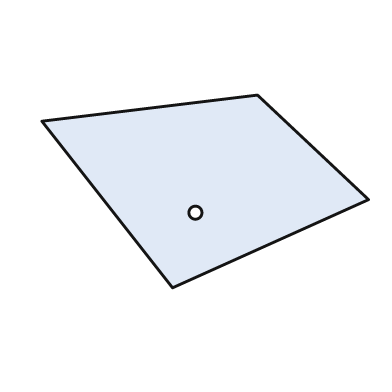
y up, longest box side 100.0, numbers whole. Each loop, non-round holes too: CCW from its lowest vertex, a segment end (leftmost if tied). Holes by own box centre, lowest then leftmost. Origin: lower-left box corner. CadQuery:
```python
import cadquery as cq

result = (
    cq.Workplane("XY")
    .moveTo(40.0, 0.0)
    .lineTo(100.0, 27.0)
    .lineTo(66.0, 59.0)
    .lineTo(0.0, 51.0)
    .close()
    .moveTo(47.0, 23.0)
    .circle(2.0)
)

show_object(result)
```